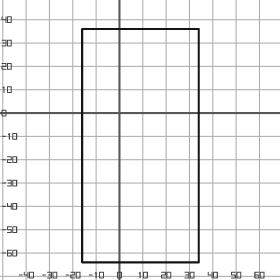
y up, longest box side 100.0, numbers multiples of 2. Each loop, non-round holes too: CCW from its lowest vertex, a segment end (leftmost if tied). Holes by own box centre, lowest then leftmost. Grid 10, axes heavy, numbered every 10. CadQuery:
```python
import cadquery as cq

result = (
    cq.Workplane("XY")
    .moveTo(-16.0, -64.0)
    .lineTo(34.0, -64.0)
    .lineTo(34.0, 36.0)
    .lineTo(-16.0, 36.0)
    .close()
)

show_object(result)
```